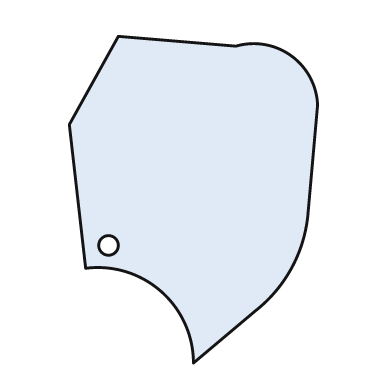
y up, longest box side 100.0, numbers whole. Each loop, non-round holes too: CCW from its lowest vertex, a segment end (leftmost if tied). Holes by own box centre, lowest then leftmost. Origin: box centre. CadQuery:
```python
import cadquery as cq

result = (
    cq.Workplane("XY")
    .moveTo(0.0, -50.0)
    .lineTo(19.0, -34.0)
    .threePointArc((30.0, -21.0), (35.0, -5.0))
    .lineTo(38.0, 29.0)
    .threePointArc((30.0, 44.0), (13.0, 47.0))
    .lineTo(-23.0, 50.0)
    .lineTo(-38.0, 23.0)
    .lineTo(-33.0, -21.0)
    .threePointArc((-10.0, -28.0), (0.0, -50.0))
    .close()
    .moveTo(-26.0, -14.0)
    .circle(3.0)
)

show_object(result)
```